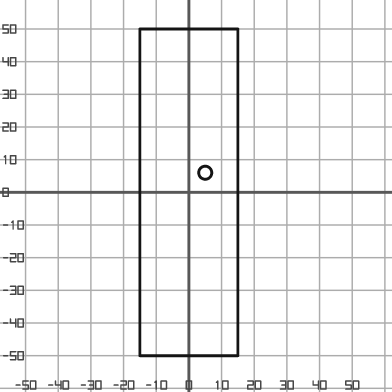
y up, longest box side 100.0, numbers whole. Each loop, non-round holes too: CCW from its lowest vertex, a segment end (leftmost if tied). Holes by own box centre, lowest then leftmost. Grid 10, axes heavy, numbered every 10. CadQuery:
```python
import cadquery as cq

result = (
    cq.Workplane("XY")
    .moveTo(-15.0, -50.0)
    .lineTo(15.0, -50.0)
    .lineTo(15.0, 50.0)
    .lineTo(-15.0, 50.0)
    .close()
    .moveTo(5.0, 6.0)
    .circle(2.0)
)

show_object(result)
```